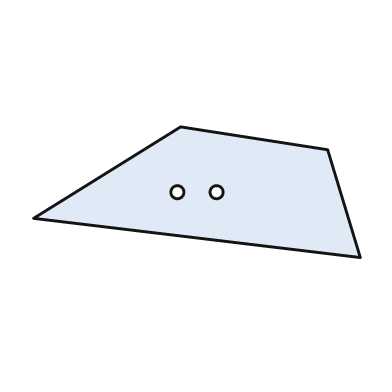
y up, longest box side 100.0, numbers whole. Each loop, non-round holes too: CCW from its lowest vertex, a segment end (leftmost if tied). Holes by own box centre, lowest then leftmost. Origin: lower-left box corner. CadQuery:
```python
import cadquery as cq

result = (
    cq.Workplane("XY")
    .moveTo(100.0, 0.0)
    .lineTo(90.0, 33.0)
    .lineTo(45.0, 40.0)
    .lineTo(0.0, 12.0)
    .close()
    .moveTo(44.0, 20.0)
    .circle(2.0)
    .moveTo(56.0, 20.0)
    .circle(2.0)
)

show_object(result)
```